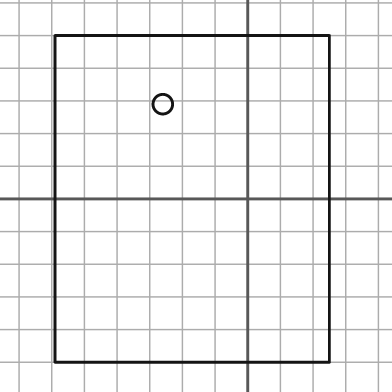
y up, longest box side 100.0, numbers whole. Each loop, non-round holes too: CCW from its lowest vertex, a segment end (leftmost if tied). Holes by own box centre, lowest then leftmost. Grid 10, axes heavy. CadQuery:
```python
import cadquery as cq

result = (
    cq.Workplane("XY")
    .moveTo(-59.0, -50.0)
    .lineTo(25.0, -50.0)
    .lineTo(25.0, 50.0)
    .lineTo(-59.0, 50.0)
    .close()
    .moveTo(-26.0, 29.0)
    .circle(3.0)
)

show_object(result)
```